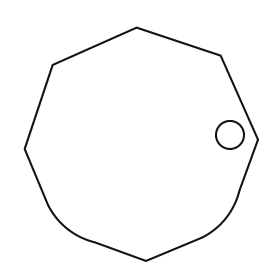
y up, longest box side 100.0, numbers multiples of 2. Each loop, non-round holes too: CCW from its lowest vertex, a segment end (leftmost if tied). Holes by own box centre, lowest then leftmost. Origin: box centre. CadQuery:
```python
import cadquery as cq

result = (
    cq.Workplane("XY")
    .moveTo(2.0, -50.0)
    .lineTo(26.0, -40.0)
    .threePointArc((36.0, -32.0), (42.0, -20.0))
    .lineTo(50.0, 2.0)
    .lineTo(34.0, 38.0)
    .lineTo(-2.0, 50.0)
    .lineTo(-38.0, 34.0)
    .lineTo(-50.0, -2.0)
    .lineTo(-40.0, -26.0)
    .threePointArc((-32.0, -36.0), (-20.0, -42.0))
    .close()
    .moveTo(38.0, 4.0)
    .circle(6.0)
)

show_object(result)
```